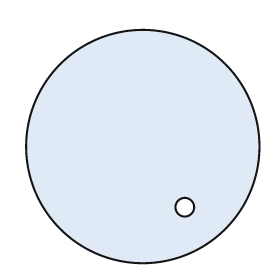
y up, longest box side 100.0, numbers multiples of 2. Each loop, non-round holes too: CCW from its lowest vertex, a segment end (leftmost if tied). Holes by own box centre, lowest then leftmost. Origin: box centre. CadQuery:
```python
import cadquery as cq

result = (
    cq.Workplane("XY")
    .moveTo(0.0, 0.0)
    .circle(50.0)
    .moveTo(18.0, -26.0)
    .circle(4.0)
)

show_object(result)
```